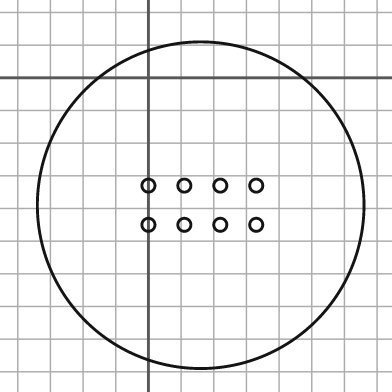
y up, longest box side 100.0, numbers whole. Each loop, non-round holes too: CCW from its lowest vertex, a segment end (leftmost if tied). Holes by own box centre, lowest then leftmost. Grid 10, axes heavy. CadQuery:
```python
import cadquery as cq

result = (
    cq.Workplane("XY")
    .moveTo(16.0, -39.0)
    .circle(50.0)
    .moveTo(0.0, -45.0)
    .circle(2.0)
    .moveTo(11.0, -45.0)
    .circle(2.0)
    .moveTo(22.0, -45.0)
    .circle(2.0)
    .moveTo(33.0, -45.0)
    .circle(2.0)
    .moveTo(0.0, -33.0)
    .circle(2.0)
    .moveTo(11.0, -33.0)
    .circle(2.0)
    .moveTo(22.0, -33.0)
    .circle(2.0)
    .moveTo(33.0, -33.0)
    .circle(2.0)
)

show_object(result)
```